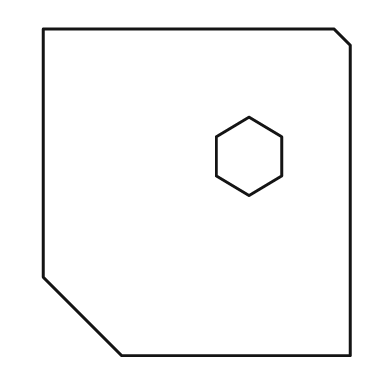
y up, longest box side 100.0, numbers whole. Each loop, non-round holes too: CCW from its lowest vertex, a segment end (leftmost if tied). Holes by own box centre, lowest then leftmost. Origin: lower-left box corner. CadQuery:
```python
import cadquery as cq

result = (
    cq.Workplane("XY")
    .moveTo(24.0, 0.0)
    .lineTo(94.0, 0.0)
    .lineTo(94.0, 95.0)
    .lineTo(89.0, 100.0)
    .lineTo(0.0, 100.0)
    .lineTo(0.0, 24.0)
    .close()
    .moveTo(63.0, 49.0)
    .lineTo(73.0, 55.0)
    .lineTo(73.0, 67.0)
    .lineTo(63.0, 73.0)
    .lineTo(53.0, 67.0)
    .lineTo(53.0, 55.0)
    .close()
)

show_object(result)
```